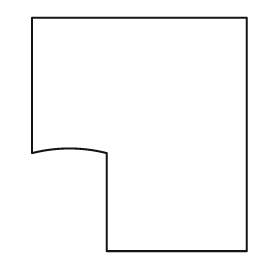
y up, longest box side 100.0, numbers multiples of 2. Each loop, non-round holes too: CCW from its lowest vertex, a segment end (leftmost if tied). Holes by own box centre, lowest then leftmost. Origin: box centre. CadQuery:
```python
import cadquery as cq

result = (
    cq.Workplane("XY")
    .moveTo(-14.0, -50.0)
    .lineTo(46.0, -50.0)
    .lineTo(46.0, 50.0)
    .lineTo(-46.0, 50.0)
    .lineTo(-46.0, -8.0)
    .threePointArc((-30.0, -6.0), (-14.0, -8.0))
    .close()
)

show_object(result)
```